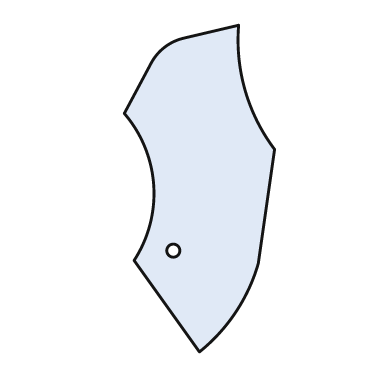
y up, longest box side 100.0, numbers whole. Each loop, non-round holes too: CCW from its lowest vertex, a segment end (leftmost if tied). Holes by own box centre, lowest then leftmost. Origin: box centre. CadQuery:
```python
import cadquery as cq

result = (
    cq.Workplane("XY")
    .moveTo(0.0, -50.0)
    .threePointArc((11.0, -38.0), (18.0, -23.0))
    .lineTo(23.0, 12.0)
    .threePointArc((14.0, 30.0), (12.0, 50.0))
    .lineTo(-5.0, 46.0)
    .threePointArc((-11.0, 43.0), (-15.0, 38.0))
    .lineTo(-23.0, 23.0)
    .threePointArc((-14.0, 1.0), (-20.0, -22.0))
    .close()
    .moveTo(-8.0, -19.0)
    .circle(2.0)
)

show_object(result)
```